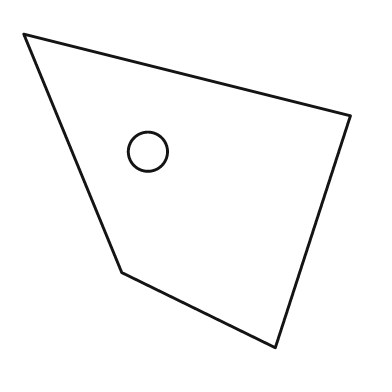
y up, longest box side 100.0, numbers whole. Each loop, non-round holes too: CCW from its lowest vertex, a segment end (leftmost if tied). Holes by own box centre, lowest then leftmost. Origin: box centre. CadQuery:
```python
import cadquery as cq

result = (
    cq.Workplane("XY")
    .moveTo(27.0, -48.0)
    .lineTo(50.0, 23.0)
    .lineTo(-50.0, 48.0)
    .lineTo(-20.0, -25.0)
    .close()
    .moveTo(-12.0, 12.0)
    .circle(6.0)
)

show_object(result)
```